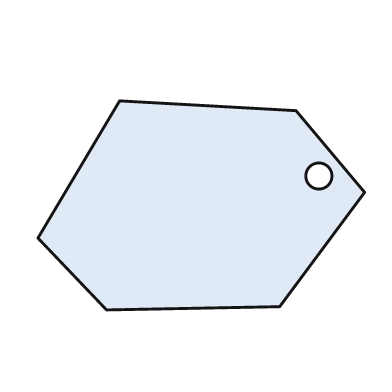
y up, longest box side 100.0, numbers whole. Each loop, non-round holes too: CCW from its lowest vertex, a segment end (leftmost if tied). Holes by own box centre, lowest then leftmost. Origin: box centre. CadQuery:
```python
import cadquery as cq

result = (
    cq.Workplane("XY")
    .moveTo(-29.0, -32.0)
    .lineTo(24.0, -31.0)
    .lineTo(50.0, 4.0)
    .lineTo(29.0, 29.0)
    .lineTo(-25.0, 32.0)
    .lineTo(-50.0, -10.0)
    .close()
    .moveTo(36.0, 9.0)
    .circle(4.0)
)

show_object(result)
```